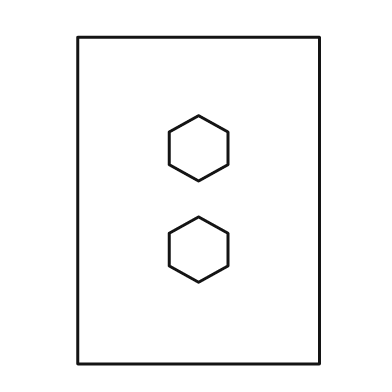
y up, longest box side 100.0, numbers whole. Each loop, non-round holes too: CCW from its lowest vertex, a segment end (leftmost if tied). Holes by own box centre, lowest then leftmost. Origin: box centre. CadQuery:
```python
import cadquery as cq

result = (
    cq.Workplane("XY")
    .moveTo(-37.0, -50.0)
    .lineTo(37.0, -50.0)
    .lineTo(37.0, 50.0)
    .lineTo(-37.0, 50.0)
    .close()
    .moveTo(0.0, -25.0)
    .lineTo(9.0, -20.0)
    .lineTo(9.0, -10.0)
    .lineTo(0.0, -5.0)
    .lineTo(-9.0, -10.0)
    .lineTo(-9.0, -20.0)
    .close()
    .moveTo(0.0, 6.0)
    .lineTo(9.0, 11.0)
    .lineTo(9.0, 21.0)
    .lineTo(0.0, 26.0)
    .lineTo(-9.0, 21.0)
    .lineTo(-9.0, 11.0)
    .close()
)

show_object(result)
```